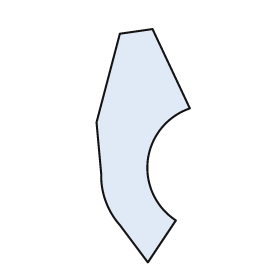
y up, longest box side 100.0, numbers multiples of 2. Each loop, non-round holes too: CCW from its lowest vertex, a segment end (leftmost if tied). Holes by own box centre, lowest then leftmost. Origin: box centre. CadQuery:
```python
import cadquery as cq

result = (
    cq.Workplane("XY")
    .moveTo(2.0, -50.0)
    .lineTo(14.0, -32.0)
    .threePointArc((2.0, -6.0), (20.0, 16.0))
    .lineTo(4.0, 50.0)
    .lineTo(-10.0, 48.0)
    .lineTo(-20.0, 10.0)
    .lineTo(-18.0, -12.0)
    .threePointArc((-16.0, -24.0), (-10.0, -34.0))
    .close()
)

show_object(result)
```